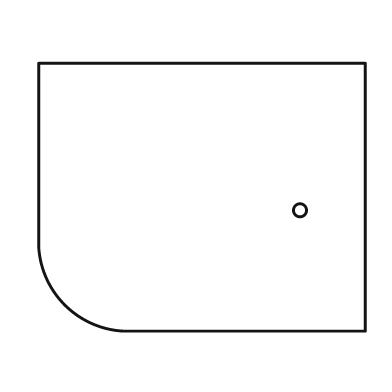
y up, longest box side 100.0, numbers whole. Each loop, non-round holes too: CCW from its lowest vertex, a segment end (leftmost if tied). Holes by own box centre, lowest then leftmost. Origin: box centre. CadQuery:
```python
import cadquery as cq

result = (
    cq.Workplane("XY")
    .moveTo(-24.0, -41.0)
    .lineTo(50.0, -41.0)
    .lineTo(50.0, 41.0)
    .lineTo(-50.0, 41.0)
    .lineTo(-50.0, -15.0)
    .threePointArc((-42.0, -33.0), (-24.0, -41.0))
    .close()
    .moveTo(30.0, -4.0)
    .circle(2.0)
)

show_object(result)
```